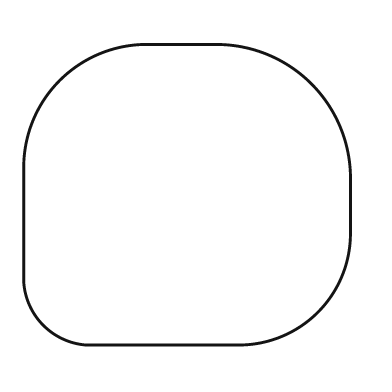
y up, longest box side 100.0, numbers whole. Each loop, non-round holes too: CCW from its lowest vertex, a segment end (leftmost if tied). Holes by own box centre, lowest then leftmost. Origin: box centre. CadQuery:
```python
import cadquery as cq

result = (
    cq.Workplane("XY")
    .moveTo(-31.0, -46.0)
    .lineTo(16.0, -46.0)
    .threePointArc((40.0, -36.0), (50.0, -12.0))
    .lineTo(50.0, 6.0)
    .threePointArc((38.0, 34.0), (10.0, 46.0))
    .lineTo(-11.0, 46.0)
    .threePointArc((-39.0, 35.0), (-50.0, 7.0))
    .lineTo(-50.0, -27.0)
    .threePointArc((-44.0, -40.0), (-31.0, -46.0))
    .close()
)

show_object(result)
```